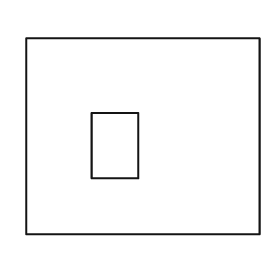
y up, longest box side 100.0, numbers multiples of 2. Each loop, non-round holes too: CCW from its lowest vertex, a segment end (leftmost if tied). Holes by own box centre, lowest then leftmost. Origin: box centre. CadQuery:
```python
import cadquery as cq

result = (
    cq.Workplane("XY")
    .moveTo(-50.0, -42.0)
    .lineTo(50.0, -42.0)
    .lineTo(50.0, 42.0)
    .lineTo(-50.0, 42.0)
    .close()
    .moveTo(-22.0, -18.0)
    .lineTo(-2.0, -18.0)
    .lineTo(-2.0, 10.0)
    .lineTo(-22.0, 10.0)
    .close()
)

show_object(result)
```